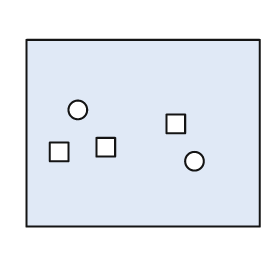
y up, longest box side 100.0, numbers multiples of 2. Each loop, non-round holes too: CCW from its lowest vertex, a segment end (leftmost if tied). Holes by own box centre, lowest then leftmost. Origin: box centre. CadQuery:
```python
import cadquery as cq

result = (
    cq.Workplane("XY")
    .moveTo(-50.0, -40.0)
    .lineTo(50.0, -40.0)
    .lineTo(50.0, 40.0)
    .lineTo(-50.0, 40.0)
    .close()
    .moveTo(22.0, -12.0)
    .circle(4.0)
    .moveTo(-40.0, -12.0)
    .lineTo(-32.0, -12.0)
    .lineTo(-32.0, -4.0)
    .lineTo(-40.0, -4.0)
    .close()
    .moveTo(-20.0, -10.0)
    .lineTo(-12.0, -10.0)
    .lineTo(-12.0, -2.0)
    .lineTo(-20.0, -2.0)
    .close()
    .moveTo(10.0, 0.0)
    .lineTo(18.0, 0.0)
    .lineTo(18.0, 8.0)
    .lineTo(10.0, 8.0)
    .close()
    .moveTo(-28.0, 10.0)
    .circle(4.0)
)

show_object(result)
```